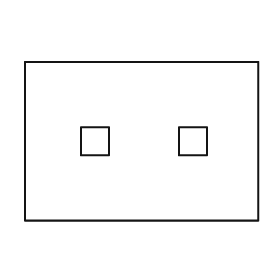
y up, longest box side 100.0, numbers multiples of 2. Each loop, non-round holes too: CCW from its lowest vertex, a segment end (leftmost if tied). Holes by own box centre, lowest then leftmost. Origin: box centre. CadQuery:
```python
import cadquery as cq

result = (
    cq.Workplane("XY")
    .moveTo(-50.0, -34.0)
    .lineTo(50.0, -34.0)
    .lineTo(50.0, 34.0)
    .lineTo(-50.0, 34.0)
    .close()
    .moveTo(-26.0, -6.0)
    .lineTo(-14.0, -6.0)
    .lineTo(-14.0, 6.0)
    .lineTo(-26.0, 6.0)
    .close()
    .moveTo(16.0, -6.0)
    .lineTo(28.0, -6.0)
    .lineTo(28.0, 6.0)
    .lineTo(16.0, 6.0)
    .close()
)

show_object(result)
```